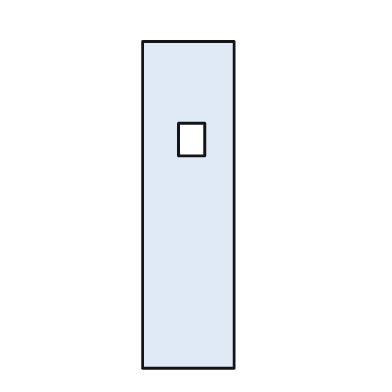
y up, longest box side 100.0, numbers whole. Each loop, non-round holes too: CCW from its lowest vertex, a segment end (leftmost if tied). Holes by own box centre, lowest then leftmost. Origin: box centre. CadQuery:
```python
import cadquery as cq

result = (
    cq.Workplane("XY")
    .moveTo(-14.0, -50.0)
    .lineTo(14.0, -50.0)
    .lineTo(14.0, 50.0)
    .lineTo(-14.0, 50.0)
    .close()
    .moveTo(-3.0, 15.0)
    .lineTo(5.0, 15.0)
    .lineTo(5.0, 25.0)
    .lineTo(-3.0, 25.0)
    .close()
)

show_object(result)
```